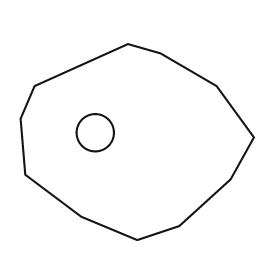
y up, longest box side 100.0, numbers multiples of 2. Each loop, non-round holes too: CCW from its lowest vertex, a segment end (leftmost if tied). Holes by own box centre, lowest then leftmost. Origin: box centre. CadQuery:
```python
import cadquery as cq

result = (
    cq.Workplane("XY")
    .moveTo(0.0, -42.0)
    .lineTo(18.0, -36.0)
    .lineTo(40.0, -16.0)
    .lineTo(50.0, 2.0)
    .lineTo(34.0, 24.0)
    .lineTo(10.0, 38.0)
    .lineTo(-4.0, 42.0)
    .lineTo(-44.0, 24.0)
    .lineTo(-50.0, 10.0)
    .lineTo(-48.0, -14.0)
    .lineTo(-24.0, -32.0)
    .close()
    .moveTo(-18.0, 4.0)
    .circle(8.0)
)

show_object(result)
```